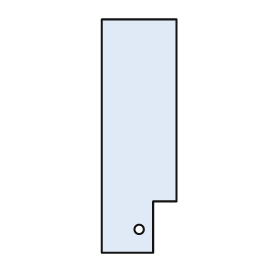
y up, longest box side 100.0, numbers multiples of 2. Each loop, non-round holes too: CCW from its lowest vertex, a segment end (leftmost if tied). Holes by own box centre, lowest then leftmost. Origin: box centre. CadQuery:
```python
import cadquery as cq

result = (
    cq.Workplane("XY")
    .moveTo(-16.0, -50.0)
    .lineTo(6.0, -50.0)
    .lineTo(6.0, -28.0)
    .lineTo(16.0, -28.0)
    .lineTo(16.0, 50.0)
    .lineTo(-16.0, 50.0)
    .close()
    .moveTo(0.0, -40.0)
    .circle(2.0)
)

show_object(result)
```